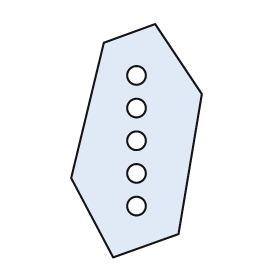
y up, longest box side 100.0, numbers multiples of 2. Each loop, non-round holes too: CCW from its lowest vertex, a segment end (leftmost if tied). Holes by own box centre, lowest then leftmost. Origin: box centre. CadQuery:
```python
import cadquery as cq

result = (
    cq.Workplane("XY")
    .moveTo(-10.0, -50.0)
    .lineTo(18.0, -40.0)
    .lineTo(28.0, 20.0)
    .lineTo(8.0, 50.0)
    .lineTo(-14.0, 42.0)
    .lineTo(-28.0, -16.0)
    .close()
    .moveTo(0.0, -28.0)
    .circle(4.0)
    .moveTo(0.0, -14.0)
    .circle(4.0)
    .moveTo(0.0, 0.0)
    .circle(4.0)
    .moveTo(0.0, 14.0)
    .circle(4.0)
    .moveTo(0.0, 28.0)
    .circle(4.0)
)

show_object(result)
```